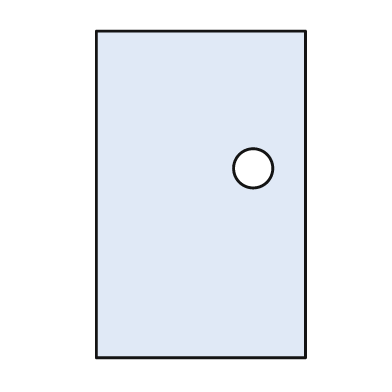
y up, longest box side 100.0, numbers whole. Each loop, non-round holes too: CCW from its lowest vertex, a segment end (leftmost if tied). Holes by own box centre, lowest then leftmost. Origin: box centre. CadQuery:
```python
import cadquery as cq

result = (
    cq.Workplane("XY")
    .moveTo(-32.0, -50.0)
    .lineTo(32.0, -50.0)
    .lineTo(32.0, 50.0)
    .lineTo(-32.0, 50.0)
    .close()
    .moveTo(16.0, 8.0)
    .circle(6.0)
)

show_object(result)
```